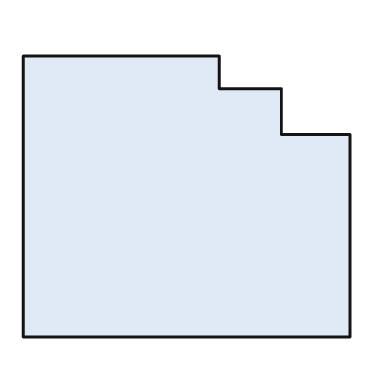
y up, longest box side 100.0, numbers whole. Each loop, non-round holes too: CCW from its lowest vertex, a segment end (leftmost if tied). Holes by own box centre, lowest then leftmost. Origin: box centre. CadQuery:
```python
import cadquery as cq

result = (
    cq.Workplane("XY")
    .moveTo(-50.0, -43.0)
    .lineTo(50.0, -43.0)
    .lineTo(50.0, 19.0)
    .lineTo(29.0, 19.0)
    .lineTo(29.0, 33.0)
    .lineTo(10.0, 33.0)
    .lineTo(10.0, 43.0)
    .lineTo(-50.0, 43.0)
    .close()
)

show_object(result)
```